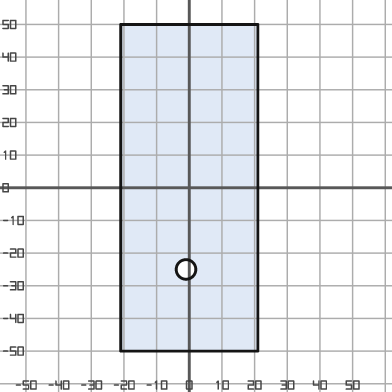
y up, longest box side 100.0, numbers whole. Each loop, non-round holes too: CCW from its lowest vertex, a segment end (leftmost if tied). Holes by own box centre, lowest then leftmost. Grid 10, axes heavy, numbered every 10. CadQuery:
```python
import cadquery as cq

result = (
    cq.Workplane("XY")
    .moveTo(-21.0, -50.0)
    .lineTo(21.0, -50.0)
    .lineTo(21.0, 50.0)
    .lineTo(-21.0, 50.0)
    .close()
    .moveTo(-1.0, -25.0)
    .circle(3.0)
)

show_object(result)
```